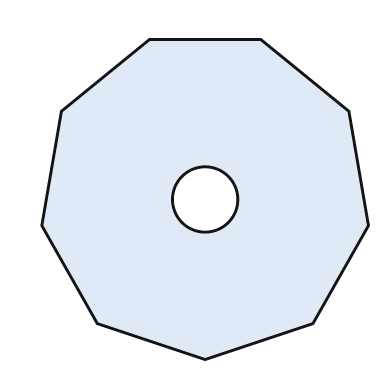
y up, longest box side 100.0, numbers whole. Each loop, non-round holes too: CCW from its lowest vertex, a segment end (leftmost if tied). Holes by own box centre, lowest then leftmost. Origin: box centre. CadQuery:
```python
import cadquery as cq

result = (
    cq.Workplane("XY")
    .moveTo(0.0, -49.0)
    .lineTo(33.0, -38.0)
    .lineTo(50.0, -8.0)
    .lineTo(44.0, 27.0)
    .lineTo(17.0, 49.0)
    .lineTo(-17.0, 49.0)
    .lineTo(-44.0, 27.0)
    .lineTo(-50.0, -8.0)
    .lineTo(-33.0, -38.0)
    .close()
    .moveTo(0.0, 0.0)
    .circle(10.0)
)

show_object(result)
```